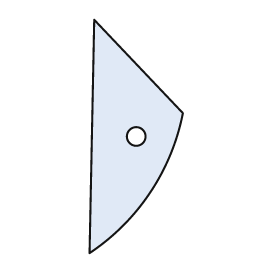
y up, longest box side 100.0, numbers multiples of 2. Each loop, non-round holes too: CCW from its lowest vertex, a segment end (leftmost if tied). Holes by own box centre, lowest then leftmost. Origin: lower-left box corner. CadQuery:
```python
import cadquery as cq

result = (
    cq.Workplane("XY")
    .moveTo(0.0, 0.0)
    .threePointArc((26.0, 26.0), (40.0, 60.0))
    .lineTo(2.0, 100.0)
    .close()
    .moveTo(20.0, 50.0)
    .circle(4.0)
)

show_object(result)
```